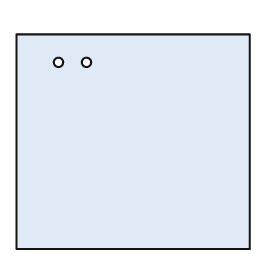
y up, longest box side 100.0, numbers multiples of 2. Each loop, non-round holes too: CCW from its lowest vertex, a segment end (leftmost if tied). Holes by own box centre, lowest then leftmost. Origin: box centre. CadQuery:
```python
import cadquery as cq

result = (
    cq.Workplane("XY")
    .moveTo(-50.0, -46.0)
    .lineTo(50.0, -46.0)
    .lineTo(50.0, 46.0)
    .lineTo(-50.0, 46.0)
    .close()
    .moveTo(-32.0, 34.0)
    .circle(2.0)
    .moveTo(-20.0, 34.0)
    .circle(2.0)
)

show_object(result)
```